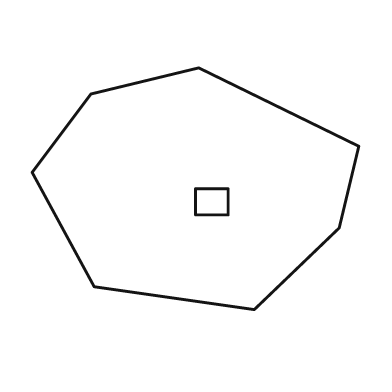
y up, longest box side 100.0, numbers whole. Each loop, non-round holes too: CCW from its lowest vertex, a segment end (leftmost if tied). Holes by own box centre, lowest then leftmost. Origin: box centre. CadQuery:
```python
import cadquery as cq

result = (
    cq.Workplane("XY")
    .moveTo(18.0, -37.0)
    .lineTo(44.0, -12.0)
    .lineTo(50.0, 13.0)
    .lineTo(1.0, 37.0)
    .lineTo(-32.0, 29.0)
    .lineTo(-50.0, 5.0)
    .lineTo(-31.0, -30.0)
    .close()
    .moveTo(0.0, -8.0)
    .lineTo(10.0, -8.0)
    .lineTo(10.0, 0.0)
    .lineTo(0.0, 0.0)
    .close()
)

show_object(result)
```